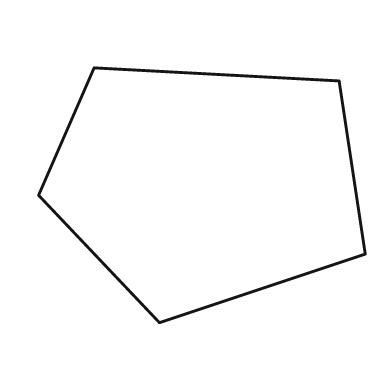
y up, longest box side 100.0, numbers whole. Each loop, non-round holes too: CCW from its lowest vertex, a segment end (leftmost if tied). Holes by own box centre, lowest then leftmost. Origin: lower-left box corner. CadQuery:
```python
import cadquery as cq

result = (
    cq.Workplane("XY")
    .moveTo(37.0, 0.0)
    .lineTo(100.0, 21.0)
    .lineTo(92.0, 74.0)
    .lineTo(17.0, 78.0)
    .lineTo(0.0, 39.0)
    .close()
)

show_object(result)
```